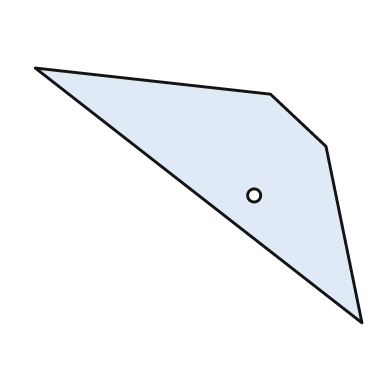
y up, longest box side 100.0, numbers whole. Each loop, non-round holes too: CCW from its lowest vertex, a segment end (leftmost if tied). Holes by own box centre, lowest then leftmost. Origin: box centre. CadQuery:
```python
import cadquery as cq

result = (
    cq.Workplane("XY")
    .moveTo(50.0, -39.0)
    .lineTo(39.0, 15.0)
    .lineTo(22.0, 31.0)
    .lineTo(-50.0, 39.0)
    .close()
    .moveTo(17.0, 0.0)
    .circle(2.0)
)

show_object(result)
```